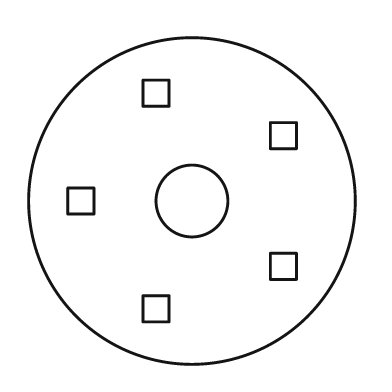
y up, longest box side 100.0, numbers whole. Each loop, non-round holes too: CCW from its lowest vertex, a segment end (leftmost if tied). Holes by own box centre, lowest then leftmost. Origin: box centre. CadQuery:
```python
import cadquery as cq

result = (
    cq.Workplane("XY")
    .moveTo(0.0, 0.0)
    .circle(50.0)
    .moveTo(-15.0, -37.0)
    .lineTo(-7.0, -37.0)
    .lineTo(-7.0, -29.0)
    .lineTo(-15.0, -29.0)
    .close()
    .moveTo(24.0, -24.0)
    .lineTo(32.0, -24.0)
    .lineTo(32.0, -16.0)
    .lineTo(24.0, -16.0)
    .close()
    .moveTo(-38.0, -4.0)
    .lineTo(-30.0, -4.0)
    .lineTo(-30.0, 4.0)
    .lineTo(-38.0, 4.0)
    .close()
    .moveTo(0.0, 0.0)
    .circle(11.0)
    .moveTo(24.0, 16.0)
    .lineTo(32.0, 16.0)
    .lineTo(32.0, 24.0)
    .lineTo(24.0, 24.0)
    .close()
    .moveTo(-15.0, 29.0)
    .lineTo(-7.0, 29.0)
    .lineTo(-7.0, 37.0)
    .lineTo(-15.0, 37.0)
    .close()
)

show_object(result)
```